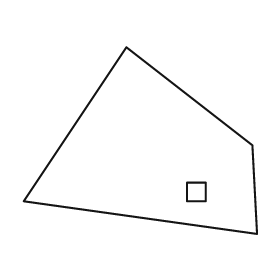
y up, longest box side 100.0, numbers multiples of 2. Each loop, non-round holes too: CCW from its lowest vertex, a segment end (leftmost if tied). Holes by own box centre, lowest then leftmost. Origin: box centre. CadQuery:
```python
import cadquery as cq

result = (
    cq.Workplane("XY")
    .moveTo(50.0, -40.0)
    .lineTo(48.0, -2.0)
    .lineTo(-6.0, 40.0)
    .lineTo(-50.0, -26.0)
    .close()
    .moveTo(20.0, -26.0)
    .lineTo(28.0, -26.0)
    .lineTo(28.0, -18.0)
    .lineTo(20.0, -18.0)
    .close()
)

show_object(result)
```